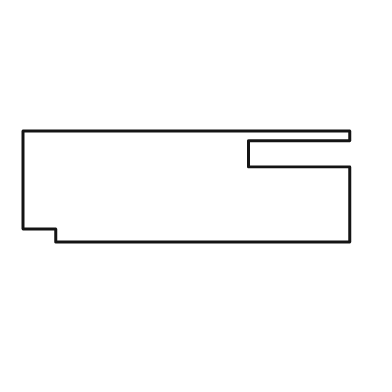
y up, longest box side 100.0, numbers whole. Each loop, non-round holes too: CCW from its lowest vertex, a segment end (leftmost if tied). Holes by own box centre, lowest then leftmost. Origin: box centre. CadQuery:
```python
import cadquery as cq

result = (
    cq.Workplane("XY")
    .moveTo(-40.0, -17.0)
    .lineTo(50.0, -17.0)
    .lineTo(50.0, 6.0)
    .lineTo(19.0, 6.0)
    .lineTo(19.0, 14.0)
    .lineTo(50.0, 14.0)
    .lineTo(50.0, 17.0)
    .lineTo(-50.0, 17.0)
    .lineTo(-50.0, -13.0)
    .lineTo(-40.0, -13.0)
    .close()
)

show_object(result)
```